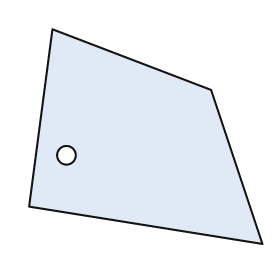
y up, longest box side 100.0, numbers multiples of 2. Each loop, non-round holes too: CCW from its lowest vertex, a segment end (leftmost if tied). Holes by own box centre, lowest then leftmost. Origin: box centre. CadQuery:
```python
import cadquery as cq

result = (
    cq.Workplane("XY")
    .moveTo(50.0, -46.0)
    .lineTo(28.0, 20.0)
    .lineTo(-40.0, 46.0)
    .lineTo(-50.0, -30.0)
    .close()
    .moveTo(-34.0, -8.0)
    .circle(4.0)
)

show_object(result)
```